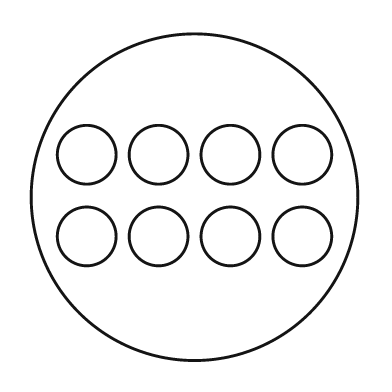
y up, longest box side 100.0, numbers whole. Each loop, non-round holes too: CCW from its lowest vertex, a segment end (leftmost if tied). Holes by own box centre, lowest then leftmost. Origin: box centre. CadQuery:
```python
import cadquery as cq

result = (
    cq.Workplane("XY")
    .moveTo(0.0, 0.0)
    .circle(50.0)
    .moveTo(-33.0, -12.0)
    .circle(9.0)
    .moveTo(-11.0, -12.0)
    .circle(9.0)
    .moveTo(11.0, -12.0)
    .circle(9.0)
    .moveTo(33.0, -12.0)
    .circle(9.0)
    .moveTo(-33.0, 13.0)
    .circle(9.0)
    .moveTo(-11.0, 13.0)
    .circle(9.0)
    .moveTo(11.0, 13.0)
    .circle(9.0)
    .moveTo(33.0, 13.0)
    .circle(9.0)
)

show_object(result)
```